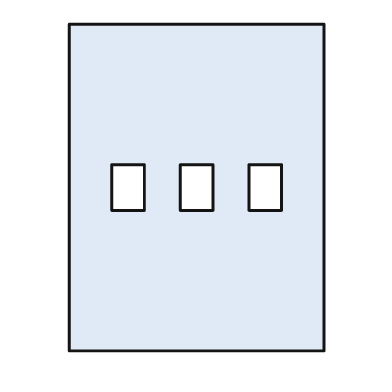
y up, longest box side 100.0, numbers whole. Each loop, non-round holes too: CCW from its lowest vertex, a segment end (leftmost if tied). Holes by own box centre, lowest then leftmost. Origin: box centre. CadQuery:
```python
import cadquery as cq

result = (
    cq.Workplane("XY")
    .moveTo(-39.0, -50.0)
    .lineTo(39.0, -50.0)
    .lineTo(39.0, 50.0)
    .lineTo(-39.0, 50.0)
    .close()
    .moveTo(-26.0, -7.0)
    .lineTo(-16.0, -7.0)
    .lineTo(-16.0, 7.0)
    .lineTo(-26.0, 7.0)
    .close()
    .moveTo(-5.0, -7.0)
    .lineTo(5.0, -7.0)
    .lineTo(5.0, 7.0)
    .lineTo(-5.0, 7.0)
    .close()
    .moveTo(16.0, -7.0)
    .lineTo(26.0, -7.0)
    .lineTo(26.0, 7.0)
    .lineTo(16.0, 7.0)
    .close()
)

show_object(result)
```